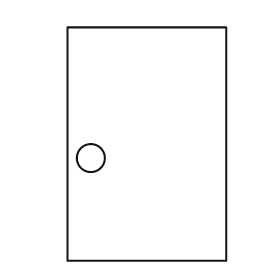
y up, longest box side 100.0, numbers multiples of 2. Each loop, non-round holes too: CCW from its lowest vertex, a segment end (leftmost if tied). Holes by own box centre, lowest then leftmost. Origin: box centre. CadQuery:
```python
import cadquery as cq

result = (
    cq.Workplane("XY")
    .moveTo(-34.0, -50.0)
    .lineTo(34.0, -50.0)
    .lineTo(34.0, 50.0)
    .lineTo(-34.0, 50.0)
    .close()
    .moveTo(-24.0, -6.0)
    .circle(6.0)
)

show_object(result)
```